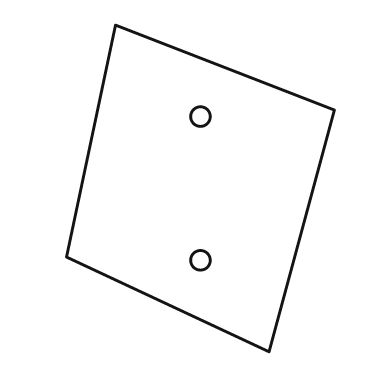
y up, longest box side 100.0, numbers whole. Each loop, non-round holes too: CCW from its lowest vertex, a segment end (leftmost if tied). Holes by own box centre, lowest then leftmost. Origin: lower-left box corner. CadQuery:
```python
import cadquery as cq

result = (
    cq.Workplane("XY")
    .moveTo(62.0, 0.0)
    .lineTo(82.0, 74.0)
    .lineTo(15.0, 100.0)
    .lineTo(0.0, 29.0)
    .close()
    .moveTo(41.0, 28.0)
    .circle(3.0)
    .moveTo(41.0, 72.0)
    .circle(3.0)
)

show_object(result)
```